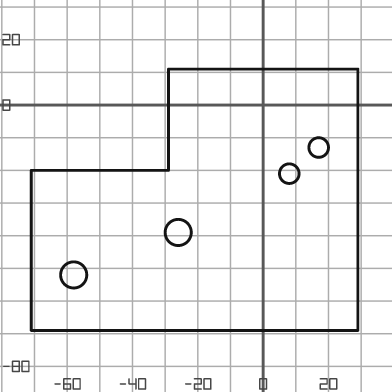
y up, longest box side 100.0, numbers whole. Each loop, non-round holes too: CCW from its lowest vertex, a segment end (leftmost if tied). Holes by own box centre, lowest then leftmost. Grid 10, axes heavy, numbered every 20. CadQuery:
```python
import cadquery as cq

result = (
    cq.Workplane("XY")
    .moveTo(-71.0, -69.0)
    .lineTo(29.0, -69.0)
    .lineTo(29.0, 11.0)
    .lineTo(-29.0, 11.0)
    .lineTo(-29.0, -20.0)
    .lineTo(-71.0, -20.0)
    .close()
    .moveTo(-58.0, -52.0)
    .circle(4.0)
    .moveTo(-26.0, -39.0)
    .circle(4.0)
    .moveTo(8.0, -21.0)
    .circle(3.0)
    .moveTo(17.0, -13.0)
    .circle(3.0)
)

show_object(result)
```